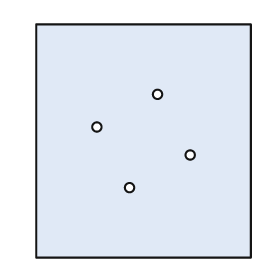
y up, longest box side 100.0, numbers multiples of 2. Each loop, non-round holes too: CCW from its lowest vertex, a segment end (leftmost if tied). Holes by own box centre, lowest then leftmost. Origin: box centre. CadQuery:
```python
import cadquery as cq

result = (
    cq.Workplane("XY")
    .moveTo(-46.0, -50.0)
    .lineTo(46.0, -50.0)
    .lineTo(46.0, 50.0)
    .lineTo(-46.0, 50.0)
    .close()
    .moveTo(-6.0, -20.0)
    .circle(2.0)
    .moveTo(20.0, -6.0)
    .circle(2.0)
    .moveTo(-20.0, 6.0)
    .circle(2.0)
    .moveTo(6.0, 20.0)
    .circle(2.0)
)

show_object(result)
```